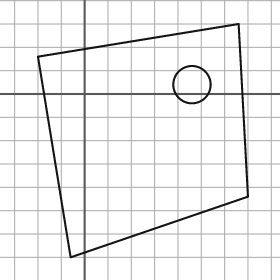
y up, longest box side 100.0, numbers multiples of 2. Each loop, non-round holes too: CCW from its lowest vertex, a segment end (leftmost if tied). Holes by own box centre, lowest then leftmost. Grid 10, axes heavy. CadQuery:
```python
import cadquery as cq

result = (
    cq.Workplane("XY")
    .moveTo(-6.0, -70.0)
    .lineTo(70.0, -44.0)
    .lineTo(66.0, 30.0)
    .lineTo(-20.0, 16.0)
    .close()
    .moveTo(46.0, 4.0)
    .circle(8.0)
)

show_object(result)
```